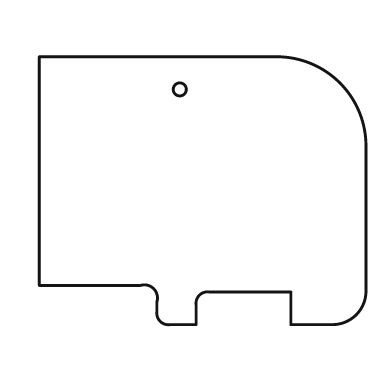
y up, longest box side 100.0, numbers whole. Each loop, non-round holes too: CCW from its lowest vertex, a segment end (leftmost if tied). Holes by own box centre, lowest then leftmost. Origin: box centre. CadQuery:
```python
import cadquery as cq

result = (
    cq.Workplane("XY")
    .moveTo(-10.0, -41.0)
    .lineTo(-2.0, -41.0)
    .lineTo(-2.0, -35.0)
    .threePointArc((-1.0, -32.0), (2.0, -31.0))
    .lineTo(27.0, -31.0)
    .lineTo(27.0, -41.0)
    .lineTo(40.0, -41.0)
    .threePointArc((47.0, -38.0), (50.0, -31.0))
    .lineTo(50.0, 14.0)
    .threePointArc((42.0, 33.0), (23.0, 41.0))
    .lineTo(-50.0, 41.0)
    .lineTo(-50.0, -29.0)
    .lineTo(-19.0, -29.0)
    .threePointArc((-15.0, -30.0), (-14.0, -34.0))
    .lineTo(-14.0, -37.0)
    .threePointArc((-13.0, -40.0), (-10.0, -41.0))
    .close()
    .moveTo(-7.0, 31.0)
    .circle(2.0)
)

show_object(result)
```